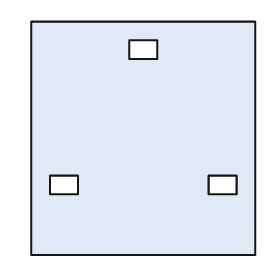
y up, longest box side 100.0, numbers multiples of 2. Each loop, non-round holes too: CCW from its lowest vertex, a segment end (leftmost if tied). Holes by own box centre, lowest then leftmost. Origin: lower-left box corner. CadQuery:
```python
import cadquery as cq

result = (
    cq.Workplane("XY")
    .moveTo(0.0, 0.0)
    .lineTo(96.0, 0.0)
    .lineTo(96.0, 100.0)
    .lineTo(0.0, 100.0)
    .close()
    .moveTo(8.0, 26.0)
    .lineTo(20.0, 26.0)
    .lineTo(20.0, 34.0)
    .lineTo(8.0, 34.0)
    .close()
    .moveTo(76.0, 26.0)
    .lineTo(88.0, 26.0)
    .lineTo(88.0, 34.0)
    .lineTo(76.0, 34.0)
    .close()
    .moveTo(42.0, 84.0)
    .lineTo(54.0, 84.0)
    .lineTo(54.0, 92.0)
    .lineTo(42.0, 92.0)
    .close()
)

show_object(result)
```